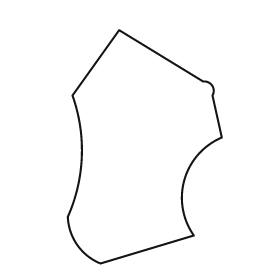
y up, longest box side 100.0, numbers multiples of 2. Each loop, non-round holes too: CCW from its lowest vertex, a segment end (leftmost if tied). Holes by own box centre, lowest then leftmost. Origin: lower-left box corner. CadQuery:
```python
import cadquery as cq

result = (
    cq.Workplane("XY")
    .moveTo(14.0, 0.0)
    .lineTo(54.0, 12.0)
    .threePointArc((50.0, 36.0), (66.0, 54.0))
    .lineTo(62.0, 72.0)
    .threePointArc((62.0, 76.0), (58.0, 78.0))
    .lineTo(22.0, 100.0)
    .lineTo(2.0, 72.0)
    .threePointArc((6.0, 46.0), (0.0, 20.0))
    .threePointArc((4.0, 8.0), (14.0, 0.0))
    .close()
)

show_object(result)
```